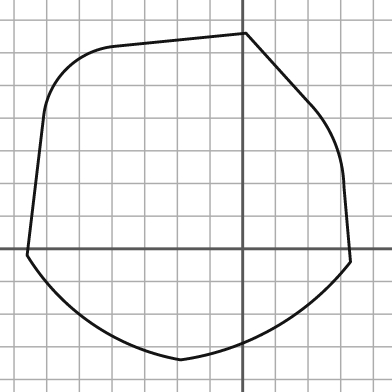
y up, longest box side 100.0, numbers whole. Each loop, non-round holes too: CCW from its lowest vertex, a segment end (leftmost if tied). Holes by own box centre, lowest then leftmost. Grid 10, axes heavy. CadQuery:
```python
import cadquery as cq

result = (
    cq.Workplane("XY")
    .moveTo(-19.0, -34.0)
    .threePointArc((10.0, -24.0), (33.0, -4.0))
    .lineTo(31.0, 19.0)
    .threePointArc((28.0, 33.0), (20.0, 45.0))
    .lineTo(1.0, 66.0)
    .lineTo(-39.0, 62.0)
    .threePointArc((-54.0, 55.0), (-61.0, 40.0))
    .lineTo(-66.0, -2.0)
    .threePointArc((-46.0, -23.0), (-19.0, -34.0))
    .close()
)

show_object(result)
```